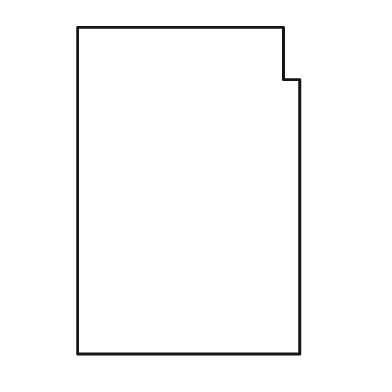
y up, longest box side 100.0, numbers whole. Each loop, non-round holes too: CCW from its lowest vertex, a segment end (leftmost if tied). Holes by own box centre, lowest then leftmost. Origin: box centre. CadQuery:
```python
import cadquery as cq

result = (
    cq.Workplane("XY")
    .moveTo(-34.0, -50.0)
    .lineTo(34.0, -50.0)
    .lineTo(34.0, 34.0)
    .lineTo(29.0, 34.0)
    .lineTo(29.0, 50.0)
    .lineTo(-34.0, 50.0)
    .close()
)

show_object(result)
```